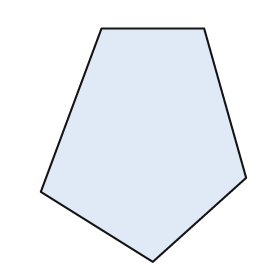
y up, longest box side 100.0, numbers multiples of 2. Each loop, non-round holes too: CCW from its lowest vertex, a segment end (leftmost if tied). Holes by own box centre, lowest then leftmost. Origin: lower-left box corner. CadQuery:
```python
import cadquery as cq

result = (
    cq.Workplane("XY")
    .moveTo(48.0, 0.0)
    .lineTo(88.0, 36.0)
    .lineTo(70.0, 100.0)
    .lineTo(26.0, 100.0)
    .lineTo(0.0, 30.0)
    .close()
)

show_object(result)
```